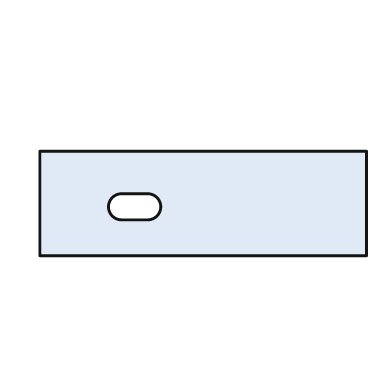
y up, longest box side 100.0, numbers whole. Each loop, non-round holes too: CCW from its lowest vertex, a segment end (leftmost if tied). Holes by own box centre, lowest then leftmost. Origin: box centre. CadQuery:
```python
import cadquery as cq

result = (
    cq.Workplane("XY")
    .moveTo(-50.0, -16.0)
    .lineTo(50.0, -16.0)
    .lineTo(50.0, 16.0)
    .lineTo(-50.0, 16.0)
    .close()
    .moveTo(-25.0, -5.0)
    .lineTo(-17.0, -5.0)
    .threePointArc((-13.0, -1.0), (-17.0, 3.0))
    .lineTo(-25.0, 3.0)
    .threePointArc((-29.0, -1.0), (-25.0, -5.0))
    .close()
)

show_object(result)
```